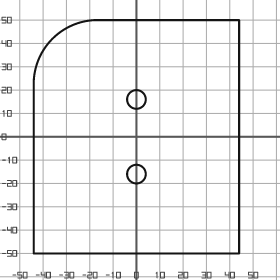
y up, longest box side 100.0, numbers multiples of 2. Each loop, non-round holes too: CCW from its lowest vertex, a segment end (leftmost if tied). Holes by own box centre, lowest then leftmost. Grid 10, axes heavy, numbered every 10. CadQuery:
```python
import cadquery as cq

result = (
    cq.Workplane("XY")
    .moveTo(-44.0, -50.0)
    .lineTo(44.0, -50.0)
    .lineTo(44.0, 50.0)
    .lineTo(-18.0, 50.0)
    .threePointArc((-36.0, 42.0), (-44.0, 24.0))
    .close()
    .moveTo(0.0, -16.0)
    .circle(4.0)
    .moveTo(0.0, 16.0)
    .circle(4.0)
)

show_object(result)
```